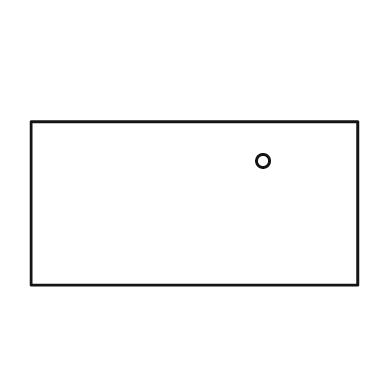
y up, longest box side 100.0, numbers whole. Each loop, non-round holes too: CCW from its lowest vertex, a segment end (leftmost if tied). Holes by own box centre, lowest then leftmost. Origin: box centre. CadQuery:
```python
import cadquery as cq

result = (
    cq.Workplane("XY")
    .moveTo(-50.0, -25.0)
    .lineTo(50.0, -25.0)
    .lineTo(50.0, 25.0)
    .lineTo(-50.0, 25.0)
    .close()
    .moveTo(21.0, 13.0)
    .circle(2.0)
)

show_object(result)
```